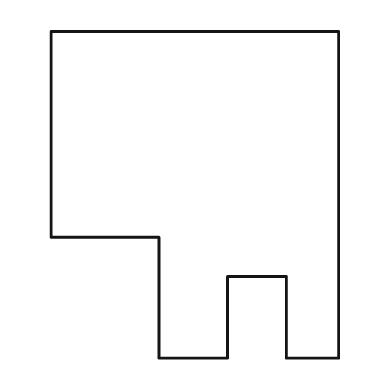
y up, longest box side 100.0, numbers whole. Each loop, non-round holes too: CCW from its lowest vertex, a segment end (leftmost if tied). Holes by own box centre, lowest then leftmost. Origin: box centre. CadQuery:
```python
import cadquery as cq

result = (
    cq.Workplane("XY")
    .moveTo(-11.0, -50.0)
    .lineTo(10.0, -50.0)
    .lineTo(10.0, -25.0)
    .lineTo(28.0, -25.0)
    .lineTo(28.0, -50.0)
    .lineTo(44.0, -50.0)
    .lineTo(44.0, 50.0)
    .lineTo(-44.0, 50.0)
    .lineTo(-44.0, -13.0)
    .lineTo(-11.0, -13.0)
    .close()
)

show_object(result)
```